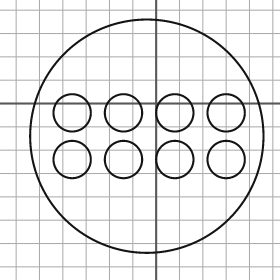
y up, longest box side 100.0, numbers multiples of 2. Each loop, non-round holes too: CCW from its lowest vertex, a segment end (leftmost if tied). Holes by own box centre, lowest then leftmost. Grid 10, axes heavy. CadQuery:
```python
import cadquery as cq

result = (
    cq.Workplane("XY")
    .moveTo(-4.0, -14.0)
    .circle(50.0)
    .moveTo(-36.0, -24.0)
    .circle(8.0)
    .moveTo(-14.0, -24.0)
    .circle(8.0)
    .moveTo(8.0, -24.0)
    .circle(8.0)
    .moveTo(30.0, -24.0)
    .circle(8.0)
    .moveTo(-36.0, -4.0)
    .circle(8.0)
    .moveTo(-14.0, -4.0)
    .circle(8.0)
    .moveTo(8.0, -4.0)
    .circle(8.0)
    .moveTo(30.0, -4.0)
    .circle(8.0)
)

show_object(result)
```